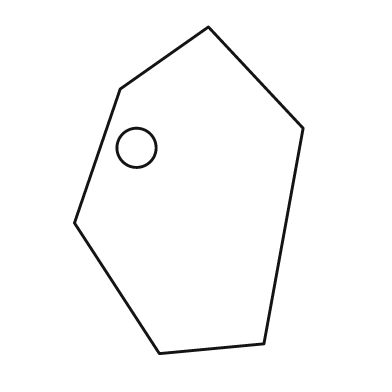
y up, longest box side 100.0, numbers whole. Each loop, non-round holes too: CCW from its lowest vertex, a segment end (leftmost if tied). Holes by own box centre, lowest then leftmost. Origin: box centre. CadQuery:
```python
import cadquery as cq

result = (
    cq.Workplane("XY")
    .moveTo(-9.0, -50.0)
    .lineTo(23.0, -47.0)
    .lineTo(35.0, 19.0)
    .lineTo(6.0, 50.0)
    .lineTo(-21.0, 31.0)
    .lineTo(-35.0, -10.0)
    .close()
    .moveTo(-16.0, 13.0)
    .circle(6.0)
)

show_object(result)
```